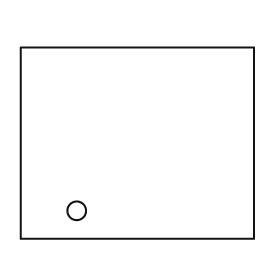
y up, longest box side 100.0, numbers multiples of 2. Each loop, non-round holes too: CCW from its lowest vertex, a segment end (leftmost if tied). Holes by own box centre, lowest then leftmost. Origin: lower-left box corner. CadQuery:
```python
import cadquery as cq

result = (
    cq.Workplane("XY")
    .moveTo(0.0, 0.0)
    .lineTo(100.0, 0.0)
    .lineTo(100.0, 82.0)
    .lineTo(0.0, 82.0)
    .close()
    .moveTo(24.0, 12.0)
    .circle(4.0)
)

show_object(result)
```